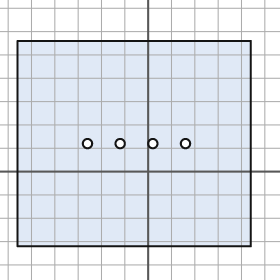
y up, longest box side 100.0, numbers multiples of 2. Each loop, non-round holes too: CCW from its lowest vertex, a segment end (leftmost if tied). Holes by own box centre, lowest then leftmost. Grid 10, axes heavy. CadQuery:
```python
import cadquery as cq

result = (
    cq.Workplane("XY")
    .moveTo(-56.0, -32.0)
    .lineTo(44.0, -32.0)
    .lineTo(44.0, 56.0)
    .lineTo(-56.0, 56.0)
    .close()
    .moveTo(-26.0, 12.0)
    .circle(2.0)
    .moveTo(-12.0, 12.0)
    .circle(2.0)
    .moveTo(2.0, 12.0)
    .circle(2.0)
    .moveTo(16.0, 12.0)
    .circle(2.0)
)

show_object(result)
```